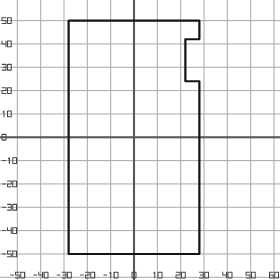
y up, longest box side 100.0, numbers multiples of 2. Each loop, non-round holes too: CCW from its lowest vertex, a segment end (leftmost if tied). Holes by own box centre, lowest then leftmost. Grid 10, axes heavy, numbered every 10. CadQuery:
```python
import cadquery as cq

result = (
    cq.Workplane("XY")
    .moveTo(-28.0, -50.0)
    .lineTo(28.0, -50.0)
    .lineTo(28.0, 24.0)
    .lineTo(22.0, 24.0)
    .lineTo(22.0, 42.0)
    .lineTo(28.0, 42.0)
    .lineTo(28.0, 50.0)
    .lineTo(-28.0, 50.0)
    .close()
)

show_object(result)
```